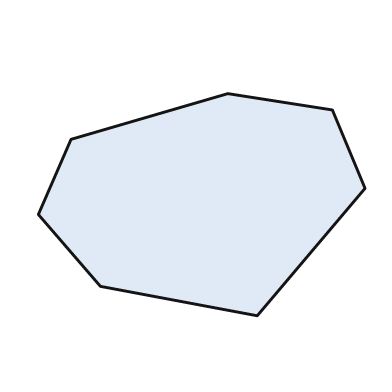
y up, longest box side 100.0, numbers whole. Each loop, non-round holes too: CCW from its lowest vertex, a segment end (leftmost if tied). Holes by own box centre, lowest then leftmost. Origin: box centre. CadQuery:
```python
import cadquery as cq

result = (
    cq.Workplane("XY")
    .moveTo(17.0, -34.0)
    .lineTo(50.0, 5.0)
    .lineTo(40.0, 29.0)
    .lineTo(8.0, 34.0)
    .lineTo(-40.0, 20.0)
    .lineTo(-50.0, -3.0)
    .lineTo(-31.0, -25.0)
    .close()
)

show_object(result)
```